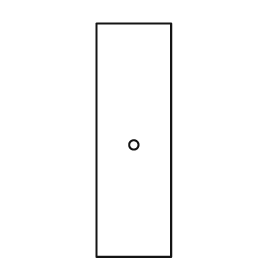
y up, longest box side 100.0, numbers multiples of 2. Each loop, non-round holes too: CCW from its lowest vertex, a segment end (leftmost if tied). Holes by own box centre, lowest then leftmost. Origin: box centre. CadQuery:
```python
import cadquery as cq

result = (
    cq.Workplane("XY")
    .moveTo(-16.0, -50.0)
    .lineTo(16.0, -50.0)
    .lineTo(16.0, 50.0)
    .lineTo(-16.0, 50.0)
    .close()
    .moveTo(0.0, -2.0)
    .circle(2.0)
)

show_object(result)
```